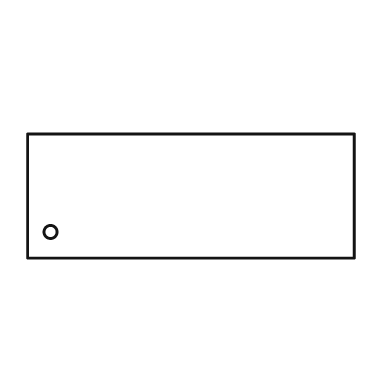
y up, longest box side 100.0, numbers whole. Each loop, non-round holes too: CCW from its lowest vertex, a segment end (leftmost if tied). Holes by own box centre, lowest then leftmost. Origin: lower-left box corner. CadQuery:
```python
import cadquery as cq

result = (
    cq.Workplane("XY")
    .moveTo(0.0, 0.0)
    .lineTo(100.0, 0.0)
    .lineTo(100.0, 38.0)
    .lineTo(0.0, 38.0)
    .close()
    .moveTo(7.0, 8.0)
    .circle(2.0)
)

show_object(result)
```